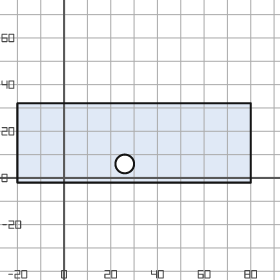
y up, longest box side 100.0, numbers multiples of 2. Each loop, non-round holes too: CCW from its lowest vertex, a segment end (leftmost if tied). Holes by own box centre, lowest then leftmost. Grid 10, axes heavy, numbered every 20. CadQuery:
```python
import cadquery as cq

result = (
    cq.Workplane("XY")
    .moveTo(-20.0, -2.0)
    .lineTo(80.0, -2.0)
    .lineTo(80.0, 32.0)
    .lineTo(-20.0, 32.0)
    .close()
    .moveTo(26.0, 6.0)
    .circle(4.0)
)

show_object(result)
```